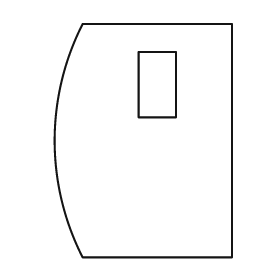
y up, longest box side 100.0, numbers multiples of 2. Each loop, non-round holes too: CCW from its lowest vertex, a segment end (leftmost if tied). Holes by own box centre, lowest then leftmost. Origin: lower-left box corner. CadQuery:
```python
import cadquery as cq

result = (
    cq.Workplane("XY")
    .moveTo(12.0, 0.0)
    .lineTo(76.0, 0.0)
    .lineTo(76.0, 100.0)
    .lineTo(12.0, 100.0)
    .threePointArc((0.0, 50.0), (12.0, 0.0))
    .close()
    .moveTo(36.0, 60.0)
    .lineTo(52.0, 60.0)
    .lineTo(52.0, 88.0)
    .lineTo(36.0, 88.0)
    .close()
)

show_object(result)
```